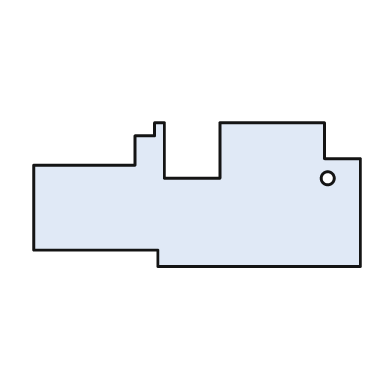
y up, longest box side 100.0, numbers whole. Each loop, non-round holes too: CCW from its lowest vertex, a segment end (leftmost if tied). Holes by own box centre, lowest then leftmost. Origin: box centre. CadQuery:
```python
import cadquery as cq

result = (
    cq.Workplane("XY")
    .moveTo(-12.0, -22.0)
    .lineTo(50.0, -22.0)
    .lineTo(50.0, 11.0)
    .lineTo(39.0, 11.0)
    .lineTo(39.0, 22.0)
    .lineTo(7.0, 22.0)
    .lineTo(7.0, 5.0)
    .lineTo(-10.0, 5.0)
    .lineTo(-10.0, 22.0)
    .lineTo(-13.0, 22.0)
    .lineTo(-13.0, 18.0)
    .lineTo(-19.0, 18.0)
    .lineTo(-19.0, 9.0)
    .lineTo(-50.0, 9.0)
    .lineTo(-50.0, -17.0)
    .lineTo(-12.0, -17.0)
    .close()
    .moveTo(40.0, 5.0)
    .circle(2.0)
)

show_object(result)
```